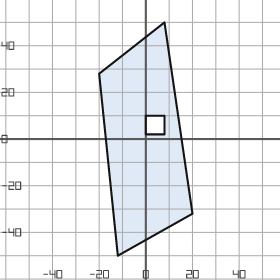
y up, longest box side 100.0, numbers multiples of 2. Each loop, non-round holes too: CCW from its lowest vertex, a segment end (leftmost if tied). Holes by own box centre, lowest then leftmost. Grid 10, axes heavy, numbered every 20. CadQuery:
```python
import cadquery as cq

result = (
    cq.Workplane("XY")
    .moveTo(-12.0, -50.0)
    .lineTo(20.0, -32.0)
    .lineTo(8.0, 50.0)
    .lineTo(-20.0, 28.0)
    .close()
    .moveTo(0.0, 2.0)
    .lineTo(8.0, 2.0)
    .lineTo(8.0, 10.0)
    .lineTo(0.0, 10.0)
    .close()
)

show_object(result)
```